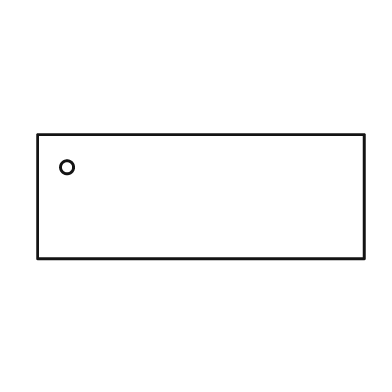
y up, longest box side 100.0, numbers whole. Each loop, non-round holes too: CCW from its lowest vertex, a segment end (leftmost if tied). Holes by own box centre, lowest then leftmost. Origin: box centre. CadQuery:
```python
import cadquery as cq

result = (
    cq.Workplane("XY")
    .moveTo(-50.0, -19.0)
    .lineTo(50.0, -19.0)
    .lineTo(50.0, 19.0)
    .lineTo(-50.0, 19.0)
    .close()
    .moveTo(-41.0, 9.0)
    .circle(2.0)
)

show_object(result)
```